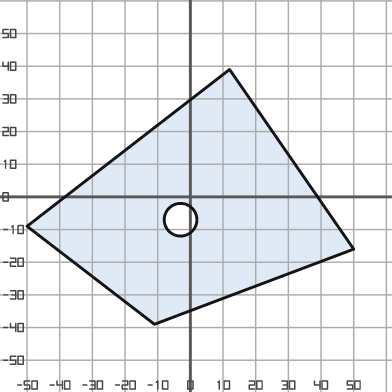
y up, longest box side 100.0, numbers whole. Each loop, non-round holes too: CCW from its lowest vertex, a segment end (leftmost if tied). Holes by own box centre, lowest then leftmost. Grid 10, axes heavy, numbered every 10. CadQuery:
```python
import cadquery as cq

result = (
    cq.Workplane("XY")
    .moveTo(-11.0, -39.0)
    .lineTo(50.0, -16.0)
    .lineTo(12.0, 39.0)
    .lineTo(-50.0, -9.0)
    .close()
    .moveTo(-3.0, -7.0)
    .circle(5.0)
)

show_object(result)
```